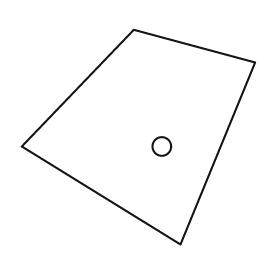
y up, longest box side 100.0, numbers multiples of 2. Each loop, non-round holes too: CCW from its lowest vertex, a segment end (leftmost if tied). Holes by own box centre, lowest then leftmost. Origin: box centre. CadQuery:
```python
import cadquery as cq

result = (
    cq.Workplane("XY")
    .moveTo(18.0, -46.0)
    .lineTo(50.0, 32.0)
    .lineTo(-2.0, 46.0)
    .lineTo(-50.0, -4.0)
    .close()
    .moveTo(10.0, -4.0)
    .circle(4.0)
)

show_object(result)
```